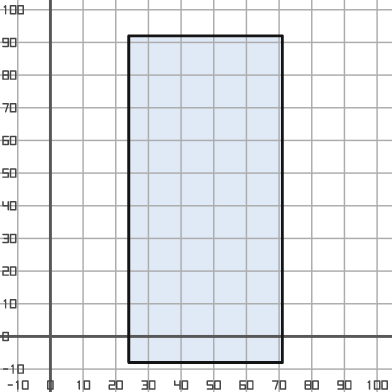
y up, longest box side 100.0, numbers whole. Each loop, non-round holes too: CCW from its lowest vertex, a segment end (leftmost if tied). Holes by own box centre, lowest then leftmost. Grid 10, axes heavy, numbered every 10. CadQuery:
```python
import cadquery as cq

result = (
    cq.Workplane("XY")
    .moveTo(24.0, -8.0)
    .lineTo(71.0, -8.0)
    .lineTo(71.0, 92.0)
    .lineTo(24.0, 92.0)
    .close()
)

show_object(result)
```